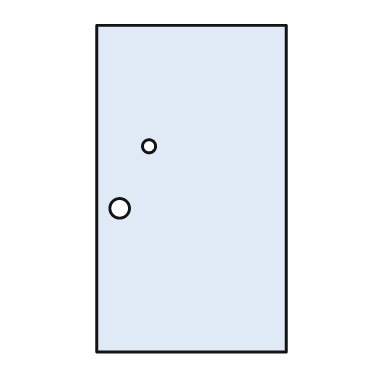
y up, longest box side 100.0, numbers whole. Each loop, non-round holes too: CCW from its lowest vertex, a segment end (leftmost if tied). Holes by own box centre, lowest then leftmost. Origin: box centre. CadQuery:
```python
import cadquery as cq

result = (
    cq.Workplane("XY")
    .moveTo(-29.0, -50.0)
    .lineTo(29.0, -50.0)
    .lineTo(29.0, 50.0)
    .lineTo(-29.0, 50.0)
    .close()
    .moveTo(-22.0, -6.0)
    .circle(3.0)
    .moveTo(-13.0, 13.0)
    .circle(2.0)
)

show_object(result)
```